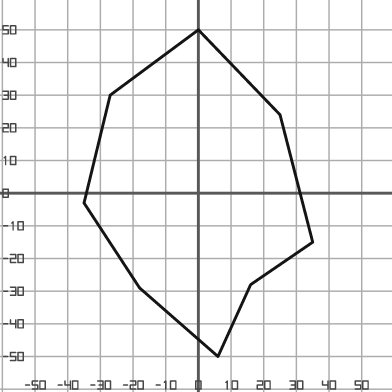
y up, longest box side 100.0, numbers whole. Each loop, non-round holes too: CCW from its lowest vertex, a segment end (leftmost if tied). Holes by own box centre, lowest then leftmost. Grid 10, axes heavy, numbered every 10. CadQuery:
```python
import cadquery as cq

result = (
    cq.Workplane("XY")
    .moveTo(6.0, -50.0)
    .lineTo(16.0, -28.0)
    .lineTo(35.0, -15.0)
    .lineTo(25.0, 24.0)
    .lineTo(0.0, 50.0)
    .lineTo(-27.0, 30.0)
    .lineTo(-35.0, -3.0)
    .lineTo(-18.0, -29.0)
    .close()
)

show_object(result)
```